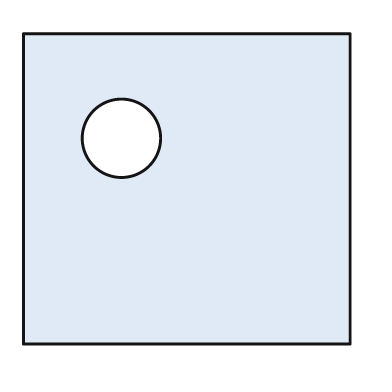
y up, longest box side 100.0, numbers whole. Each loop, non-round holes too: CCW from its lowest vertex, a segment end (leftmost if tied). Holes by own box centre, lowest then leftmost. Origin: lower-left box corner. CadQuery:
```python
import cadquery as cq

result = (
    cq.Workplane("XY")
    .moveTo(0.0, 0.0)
    .lineTo(100.0, 0.0)
    .lineTo(100.0, 95.0)
    .lineTo(0.0, 95.0)
    .close()
    .moveTo(30.0, 63.0)
    .circle(12.0)
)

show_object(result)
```